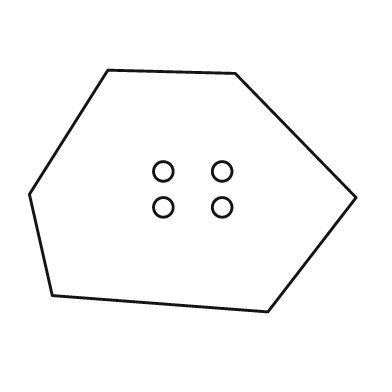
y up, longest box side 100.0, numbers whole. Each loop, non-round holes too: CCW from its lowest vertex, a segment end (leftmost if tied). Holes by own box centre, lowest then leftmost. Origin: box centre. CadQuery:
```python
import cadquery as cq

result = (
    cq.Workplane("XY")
    .moveTo(23.0, -37.0)
    .lineTo(50.0, -2.0)
    .lineTo(13.0, 36.0)
    .lineTo(-26.0, 37.0)
    .lineTo(-50.0, -1.0)
    .lineTo(-43.0, -32.0)
    .close()
    .moveTo(-9.0, -5.0)
    .circle(3.0)
    .moveTo(9.0, -5.0)
    .circle(3.0)
    .moveTo(-9.0, 6.0)
    .circle(3.0)
    .moveTo(9.0, 6.0)
    .circle(3.0)
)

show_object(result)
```